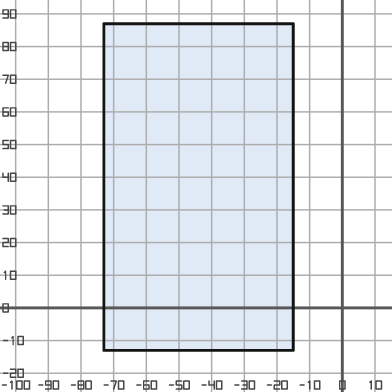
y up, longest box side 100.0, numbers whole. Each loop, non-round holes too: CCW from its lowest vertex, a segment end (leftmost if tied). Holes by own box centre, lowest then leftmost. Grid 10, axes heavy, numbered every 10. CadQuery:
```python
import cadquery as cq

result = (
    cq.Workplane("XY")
    .moveTo(-73.0, -13.0)
    .lineTo(-15.0, -13.0)
    .lineTo(-15.0, 87.0)
    .lineTo(-73.0, 87.0)
    .close()
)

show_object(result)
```